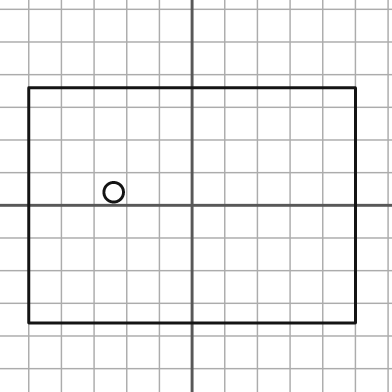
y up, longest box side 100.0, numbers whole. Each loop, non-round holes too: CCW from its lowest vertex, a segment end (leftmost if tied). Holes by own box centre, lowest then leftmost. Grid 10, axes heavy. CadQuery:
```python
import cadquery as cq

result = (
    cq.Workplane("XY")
    .moveTo(-50.0, -36.0)
    .lineTo(50.0, -36.0)
    .lineTo(50.0, 36.0)
    .lineTo(-50.0, 36.0)
    .close()
    .moveTo(-24.0, 4.0)
    .circle(3.0)
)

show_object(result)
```